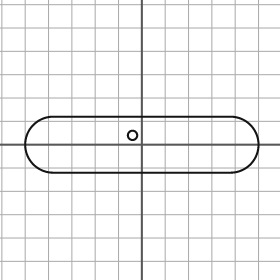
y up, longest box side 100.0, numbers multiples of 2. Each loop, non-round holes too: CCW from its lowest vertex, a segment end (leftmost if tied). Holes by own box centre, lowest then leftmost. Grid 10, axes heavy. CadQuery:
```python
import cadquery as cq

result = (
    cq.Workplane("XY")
    .moveTo(-38.0, -12.0)
    .lineTo(38.0, -12.0)
    .threePointArc((50.0, 0.0), (38.0, 12.0))
    .lineTo(-38.0, 12.0)
    .threePointArc((-50.0, 0.0), (-38.0, -12.0))
    .close()
    .moveTo(-4.0, 4.0)
    .circle(2.0)
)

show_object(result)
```